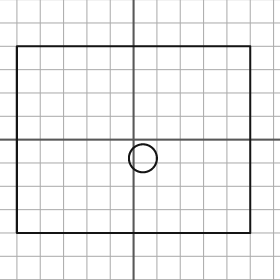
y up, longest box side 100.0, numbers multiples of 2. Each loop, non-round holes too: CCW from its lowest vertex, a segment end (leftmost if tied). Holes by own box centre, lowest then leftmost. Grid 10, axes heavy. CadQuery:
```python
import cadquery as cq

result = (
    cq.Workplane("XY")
    .moveTo(-50.0, -40.0)
    .lineTo(50.0, -40.0)
    .lineTo(50.0, 40.0)
    .lineTo(-50.0, 40.0)
    .close()
    .moveTo(4.0, -8.0)
    .circle(6.0)
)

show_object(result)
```